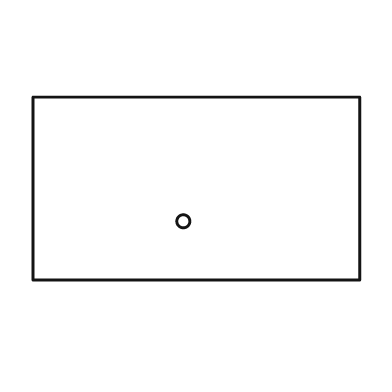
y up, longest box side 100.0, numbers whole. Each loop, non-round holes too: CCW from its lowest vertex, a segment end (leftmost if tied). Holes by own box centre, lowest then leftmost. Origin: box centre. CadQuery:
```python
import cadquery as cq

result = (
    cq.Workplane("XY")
    .moveTo(-50.0, -28.0)
    .lineTo(50.0, -28.0)
    .lineTo(50.0, 28.0)
    .lineTo(-50.0, 28.0)
    .close()
    .moveTo(-4.0, -10.0)
    .circle(2.0)
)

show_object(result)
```